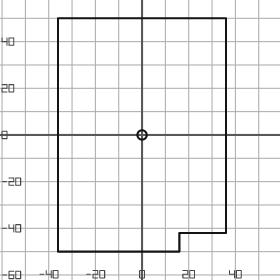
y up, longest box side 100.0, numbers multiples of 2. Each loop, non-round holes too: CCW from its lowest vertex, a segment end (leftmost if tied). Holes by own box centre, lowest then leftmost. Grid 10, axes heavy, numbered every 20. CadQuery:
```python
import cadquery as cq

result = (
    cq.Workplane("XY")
    .moveTo(-36.0, -50.0)
    .lineTo(16.0, -50.0)
    .lineTo(16.0, -42.0)
    .lineTo(36.0, -42.0)
    .lineTo(36.0, 50.0)
    .lineTo(-36.0, 50.0)
    .close()
    .moveTo(0.0, 0.0)
    .circle(2.0)
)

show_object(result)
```